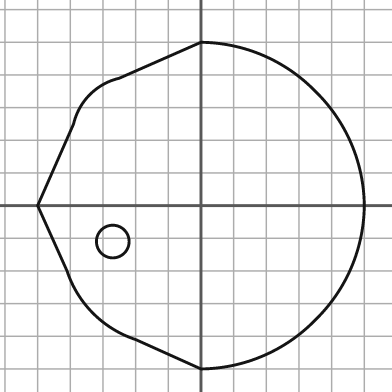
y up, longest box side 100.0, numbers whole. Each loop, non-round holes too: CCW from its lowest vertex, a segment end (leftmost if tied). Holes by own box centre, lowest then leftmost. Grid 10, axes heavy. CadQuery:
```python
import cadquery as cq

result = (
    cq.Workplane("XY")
    .moveTo(0.0, -50.0)
    .threePointArc((19.0, -46.0), (35.0, -35.0))
    .threePointArc((46.0, -19.0), (50.0, 0.0))
    .threePointArc((46.0, 19.0), (35.0, 35.0))
    .threePointArc((19.0, 46.0), (0.0, 50.0))
    .lineTo(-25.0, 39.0)
    .threePointArc((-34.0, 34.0), (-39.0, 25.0))
    .lineTo(-50.0, 0.0)
    .lineTo(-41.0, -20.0)
    .threePointArc((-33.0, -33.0), (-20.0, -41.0))
    .close()
    .moveTo(-27.0, -11.0)
    .circle(5.0)
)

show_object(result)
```